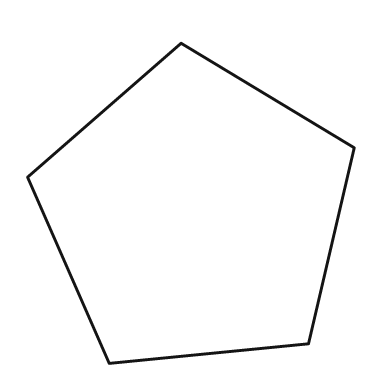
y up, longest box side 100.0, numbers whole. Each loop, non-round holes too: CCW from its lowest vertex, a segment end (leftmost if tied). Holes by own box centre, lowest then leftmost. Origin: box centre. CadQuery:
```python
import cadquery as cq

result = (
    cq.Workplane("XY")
    .moveTo(-25.0, -49.0)
    .lineTo(36.0, -43.0)
    .lineTo(50.0, 17.0)
    .lineTo(-3.0, 49.0)
    .lineTo(-50.0, 8.0)
    .close()
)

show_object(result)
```